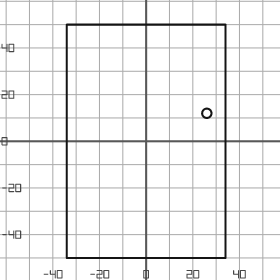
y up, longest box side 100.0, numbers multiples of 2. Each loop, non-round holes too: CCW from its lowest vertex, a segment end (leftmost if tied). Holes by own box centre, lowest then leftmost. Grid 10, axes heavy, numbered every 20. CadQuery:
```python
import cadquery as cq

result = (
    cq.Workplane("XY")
    .moveTo(-34.0, -50.0)
    .lineTo(34.0, -50.0)
    .lineTo(34.0, 50.0)
    .lineTo(-34.0, 50.0)
    .close()
    .moveTo(26.0, 12.0)
    .circle(2.0)
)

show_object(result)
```